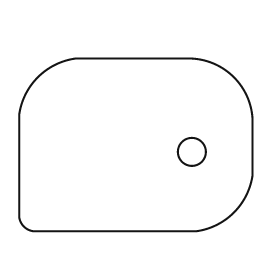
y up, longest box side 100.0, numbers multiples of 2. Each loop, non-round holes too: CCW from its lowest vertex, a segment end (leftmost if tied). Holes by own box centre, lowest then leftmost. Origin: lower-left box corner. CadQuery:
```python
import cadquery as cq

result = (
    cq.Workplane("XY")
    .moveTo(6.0, 0.0)
    .lineTo(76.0, 0.0)
    .threePointArc((92.0, 8.0), (100.0, 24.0))
    .lineTo(100.0, 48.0)
    .threePointArc((92.0, 66.0), (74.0, 74.0))
    .lineTo(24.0, 74.0)
    .threePointArc((8.0, 66.0), (0.0, 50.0))
    .lineTo(0.0, 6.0)
    .threePointArc((2.0, 2.0), (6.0, 0.0))
    .close()
    .moveTo(74.0, 34.0)
    .circle(6.0)
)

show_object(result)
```